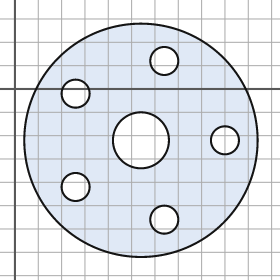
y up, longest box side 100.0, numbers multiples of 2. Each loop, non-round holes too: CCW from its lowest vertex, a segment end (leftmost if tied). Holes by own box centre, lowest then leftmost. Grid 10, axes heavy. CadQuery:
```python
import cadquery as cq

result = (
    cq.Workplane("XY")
    .moveTo(54.0, -22.0)
    .circle(50.0)
    .moveTo(64.0, -56.0)
    .circle(6.0)
    .moveTo(26.0, -42.0)
    .circle(6.0)
    .moveTo(54.0, -22.0)
    .circle(12.0)
    .moveTo(90.0, -22.0)
    .circle(6.0)
    .moveTo(26.0, -2.0)
    .circle(6.0)
    .moveTo(64.0, 12.0)
    .circle(6.0)
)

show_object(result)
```